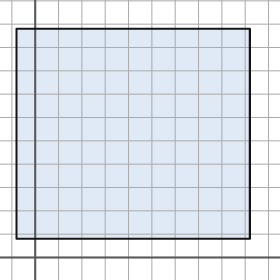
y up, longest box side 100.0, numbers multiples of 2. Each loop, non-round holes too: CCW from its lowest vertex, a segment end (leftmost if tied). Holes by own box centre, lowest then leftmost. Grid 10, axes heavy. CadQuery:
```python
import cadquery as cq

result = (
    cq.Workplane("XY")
    .moveTo(-8.0, 8.0)
    .lineTo(92.0, 8.0)
    .lineTo(92.0, 98.0)
    .lineTo(-8.0, 98.0)
    .close()
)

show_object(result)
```